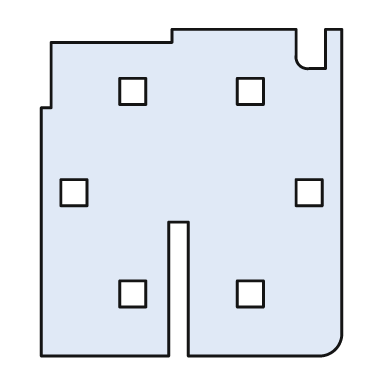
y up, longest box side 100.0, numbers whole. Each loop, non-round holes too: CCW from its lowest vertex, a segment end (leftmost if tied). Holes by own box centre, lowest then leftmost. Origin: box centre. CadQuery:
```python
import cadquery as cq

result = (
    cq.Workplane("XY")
    .moveTo(-46.0, -50.0)
    .lineTo(-7.0, -50.0)
    .lineTo(-7.0, -9.0)
    .lineTo(-1.0, -9.0)
    .lineTo(-1.0, -50.0)
    .lineTo(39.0, -50.0)
    .threePointArc((44.0, -48.0), (46.0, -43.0))
    .lineTo(46.0, 50.0)
    .lineTo(41.0, 50.0)
    .lineTo(41.0, 38.0)
    .lineTo(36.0, 38.0)
    .threePointArc((33.0, 39.0), (32.0, 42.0))
    .lineTo(32.0, 50.0)
    .lineTo(-6.0, 50.0)
    .lineTo(-6.0, 46.0)
    .lineTo(-43.0, 46.0)
    .lineTo(-43.0, 26.0)
    .lineTo(-46.0, 26.0)
    .close()
    .moveTo(-22.0, -35.0)
    .lineTo(-14.0, -35.0)
    .lineTo(-14.0, -27.0)
    .lineTo(-22.0, -27.0)
    .close()
    .moveTo(14.0, -35.0)
    .lineTo(22.0, -35.0)
    .lineTo(22.0, -27.0)
    .lineTo(14.0, -27.0)
    .close()
    .moveTo(-40.0, -4.0)
    .lineTo(-32.0, -4.0)
    .lineTo(-32.0, 4.0)
    .lineTo(-40.0, 4.0)
    .close()
    .moveTo(32.0, -4.0)
    .lineTo(40.0, -4.0)
    .lineTo(40.0, 4.0)
    .lineTo(32.0, 4.0)
    .close()
    .moveTo(-22.0, 27.0)
    .lineTo(-14.0, 27.0)
    .lineTo(-14.0, 35.0)
    .lineTo(-22.0, 35.0)
    .close()
    .moveTo(14.0, 27.0)
    .lineTo(22.0, 27.0)
    .lineTo(22.0, 35.0)
    .lineTo(14.0, 35.0)
    .close()
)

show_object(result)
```